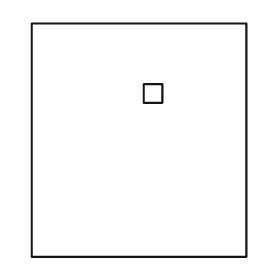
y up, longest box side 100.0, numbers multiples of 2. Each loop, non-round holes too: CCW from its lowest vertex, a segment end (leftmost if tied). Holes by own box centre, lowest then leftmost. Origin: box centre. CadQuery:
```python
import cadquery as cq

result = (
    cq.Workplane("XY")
    .moveTo(-46.0, -50.0)
    .lineTo(46.0, -50.0)
    .lineTo(46.0, 50.0)
    .lineTo(-46.0, 50.0)
    .close()
    .moveTo(2.0, 16.0)
    .lineTo(10.0, 16.0)
    .lineTo(10.0, 24.0)
    .lineTo(2.0, 24.0)
    .close()
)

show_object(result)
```